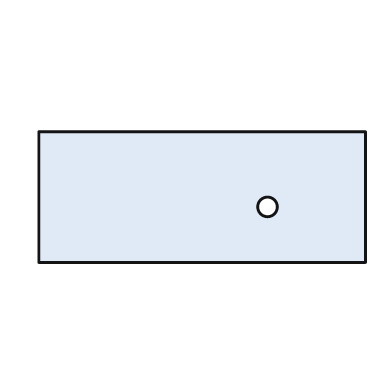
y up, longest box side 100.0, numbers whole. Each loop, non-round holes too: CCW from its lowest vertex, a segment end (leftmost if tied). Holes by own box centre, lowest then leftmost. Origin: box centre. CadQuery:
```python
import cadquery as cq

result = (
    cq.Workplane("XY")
    .moveTo(-50.0, -20.0)
    .lineTo(50.0, -20.0)
    .lineTo(50.0, 20.0)
    .lineTo(-50.0, 20.0)
    .close()
    .moveTo(20.0, -3.0)
    .circle(3.0)
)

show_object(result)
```